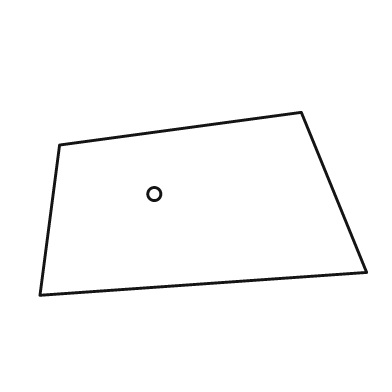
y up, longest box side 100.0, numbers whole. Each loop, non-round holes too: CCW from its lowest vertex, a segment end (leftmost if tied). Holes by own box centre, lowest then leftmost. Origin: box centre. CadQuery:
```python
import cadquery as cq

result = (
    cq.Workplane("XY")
    .moveTo(-50.0, -28.0)
    .lineTo(50.0, -21.0)
    .lineTo(30.0, 28.0)
    .lineTo(-44.0, 18.0)
    .close()
    .moveTo(-15.0, 3.0)
    .circle(2.0)
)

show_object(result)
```